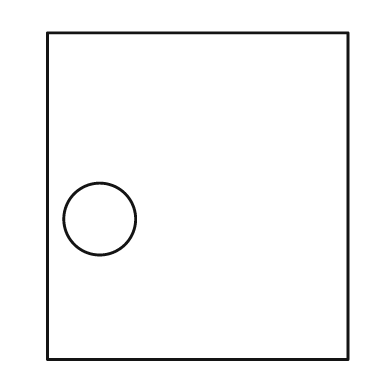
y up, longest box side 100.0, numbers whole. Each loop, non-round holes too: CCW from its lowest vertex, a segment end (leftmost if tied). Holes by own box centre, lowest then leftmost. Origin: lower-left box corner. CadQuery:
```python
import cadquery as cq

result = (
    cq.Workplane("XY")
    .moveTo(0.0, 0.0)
    .lineTo(92.0, 0.0)
    .lineTo(92.0, 100.0)
    .lineTo(0.0, 100.0)
    .close()
    .moveTo(16.0, 43.0)
    .circle(11.0)
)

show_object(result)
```